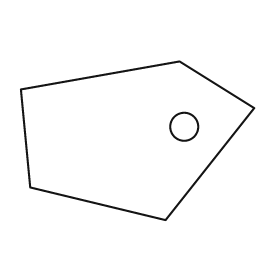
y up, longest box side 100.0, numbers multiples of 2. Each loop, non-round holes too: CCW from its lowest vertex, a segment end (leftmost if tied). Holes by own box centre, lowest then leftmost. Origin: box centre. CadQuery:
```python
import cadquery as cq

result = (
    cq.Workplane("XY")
    .moveTo(12.0, -34.0)
    .lineTo(50.0, 14.0)
    .lineTo(18.0, 34.0)
    .lineTo(-50.0, 22.0)
    .lineTo(-46.0, -20.0)
    .close()
    .moveTo(20.0, 6.0)
    .circle(6.0)
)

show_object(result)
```